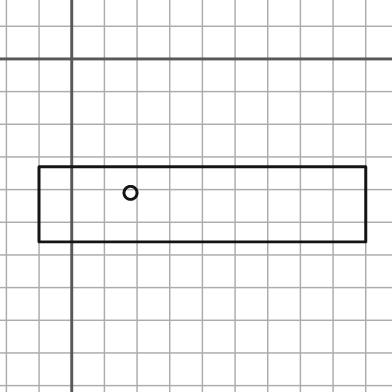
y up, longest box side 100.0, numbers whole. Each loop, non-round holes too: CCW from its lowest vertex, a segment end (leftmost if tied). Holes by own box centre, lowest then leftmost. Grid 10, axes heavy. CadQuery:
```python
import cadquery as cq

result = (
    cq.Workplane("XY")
    .moveTo(-10.0, -56.0)
    .lineTo(90.0, -56.0)
    .lineTo(90.0, -33.0)
    .lineTo(-10.0, -33.0)
    .close()
    .moveTo(18.0, -41.0)
    .circle(2.0)
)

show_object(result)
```